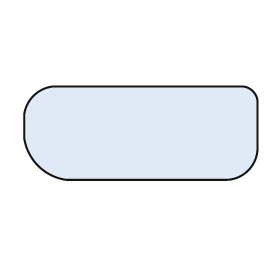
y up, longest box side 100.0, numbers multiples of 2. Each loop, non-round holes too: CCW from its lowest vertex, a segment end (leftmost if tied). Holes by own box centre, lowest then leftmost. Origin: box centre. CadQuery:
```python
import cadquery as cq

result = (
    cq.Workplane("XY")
    .moveTo(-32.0, -20.0)
    .lineTo(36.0, -20.0)
    .threePointArc((46.0, -16.0), (50.0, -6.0))
    .lineTo(50.0, 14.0)
    .threePointArc((48.0, 18.0), (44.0, 20.0))
    .lineTo(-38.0, 20.0)
    .threePointArc((-46.0, 16.0), (-50.0, 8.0))
    .lineTo(-50.0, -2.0)
    .threePointArc((-44.0, -14.0), (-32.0, -20.0))
    .close()
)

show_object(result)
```